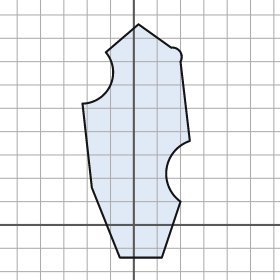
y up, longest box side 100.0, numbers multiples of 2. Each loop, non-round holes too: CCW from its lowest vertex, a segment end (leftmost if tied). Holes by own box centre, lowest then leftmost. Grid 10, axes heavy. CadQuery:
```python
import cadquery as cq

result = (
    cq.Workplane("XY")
    .moveTo(-6.0, -14.0)
    .lineTo(12.0, -14.0)
    .lineTo(20.0, 10.0)
    .threePointArc((14.0, 24.0), (24.0, 36.0))
    .lineTo(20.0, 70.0)
    .threePointArc((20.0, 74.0), (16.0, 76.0))
    .lineTo(2.0, 86.0)
    .lineTo(-12.0, 74.0)
    .threePointArc((-10.0, 60.0), (-22.0, 52.0))
    .lineTo(-18.0, 16.0)
    .close()
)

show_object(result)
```